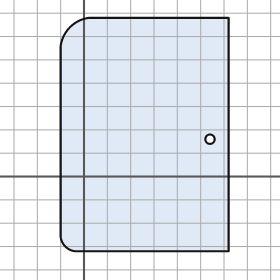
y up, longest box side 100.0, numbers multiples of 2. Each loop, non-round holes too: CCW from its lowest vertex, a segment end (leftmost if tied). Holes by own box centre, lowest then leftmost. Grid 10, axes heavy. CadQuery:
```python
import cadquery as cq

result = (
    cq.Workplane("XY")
    .moveTo(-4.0, -32.0)
    .lineTo(62.0, -32.0)
    .lineTo(62.0, 68.0)
    .lineTo(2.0, 68.0)
    .threePointArc((-6.0, 64.0), (-10.0, 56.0))
    .lineTo(-10.0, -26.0)
    .threePointArc((-8.0, -30.0), (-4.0, -32.0))
    .close()
    .moveTo(54.0, 16.0)
    .circle(2.0)
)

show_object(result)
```